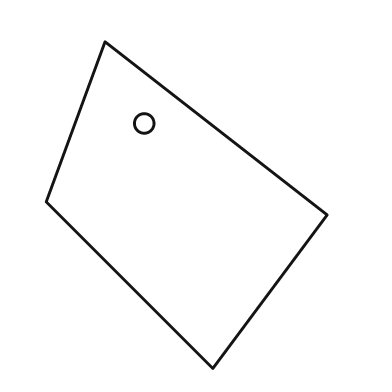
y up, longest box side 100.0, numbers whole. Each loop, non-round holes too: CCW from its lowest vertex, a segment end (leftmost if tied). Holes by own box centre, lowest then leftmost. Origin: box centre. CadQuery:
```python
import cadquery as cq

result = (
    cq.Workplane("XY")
    .moveTo(8.0, -50.0)
    .lineTo(43.0, -3.0)
    .lineTo(-25.0, 50.0)
    .lineTo(-43.0, 1.0)
    .close()
    .moveTo(-13.0, 25.0)
    .circle(3.0)
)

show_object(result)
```